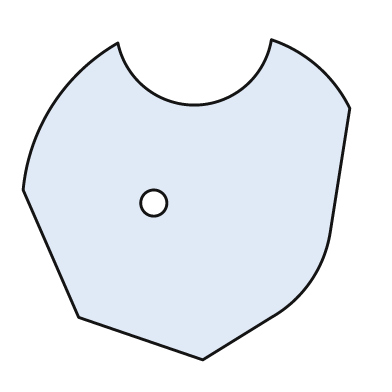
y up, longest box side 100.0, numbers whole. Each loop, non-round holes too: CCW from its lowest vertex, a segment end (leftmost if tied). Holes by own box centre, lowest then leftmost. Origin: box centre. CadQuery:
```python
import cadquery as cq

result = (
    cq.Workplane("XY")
    .moveTo(5.0, -49.0)
    .lineTo(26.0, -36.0)
    .threePointArc((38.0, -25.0), (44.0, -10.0))
    .lineTo(50.0, 28.0)
    .threePointArc((40.0, 41.0), (26.0, 49.0))
    .threePointArc((3.0, 29.0), (-21.0, 48.0))
    .threePointArc((-41.0, 29.0), (-50.0, 3.0))
    .lineTo(-33.0, -36.0)
    .close()
    .moveTo(-10.0, -1.0)
    .circle(4.0)
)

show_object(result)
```